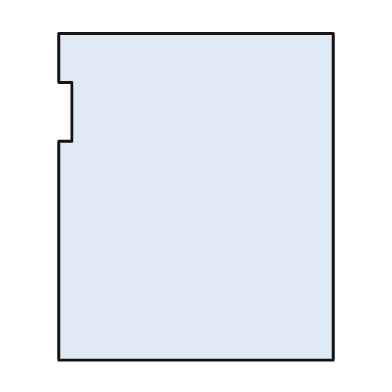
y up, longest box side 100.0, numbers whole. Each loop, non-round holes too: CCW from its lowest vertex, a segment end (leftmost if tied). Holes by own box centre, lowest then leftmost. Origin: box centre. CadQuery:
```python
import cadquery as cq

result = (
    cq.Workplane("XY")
    .moveTo(-42.0, -50.0)
    .lineTo(42.0, -50.0)
    .lineTo(42.0, 50.0)
    .lineTo(-42.0, 50.0)
    .lineTo(-42.0, 35.0)
    .lineTo(-38.0, 35.0)
    .lineTo(-38.0, 17.0)
    .lineTo(-42.0, 17.0)
    .close()
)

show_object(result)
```